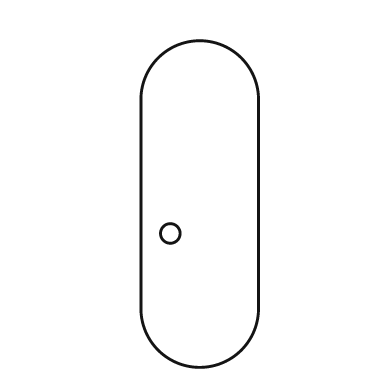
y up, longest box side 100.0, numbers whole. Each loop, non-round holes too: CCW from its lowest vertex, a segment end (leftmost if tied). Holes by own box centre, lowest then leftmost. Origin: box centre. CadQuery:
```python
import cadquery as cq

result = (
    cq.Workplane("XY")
    .moveTo(-18.0, -32.0)
    .threePointArc((0.0, -50.0), (18.0, -32.0))
    .lineTo(18.0, 32.0)
    .threePointArc((0.0, 50.0), (-18.0, 32.0))
    .close()
    .moveTo(-9.0, -9.0)
    .circle(3.0)
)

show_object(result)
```